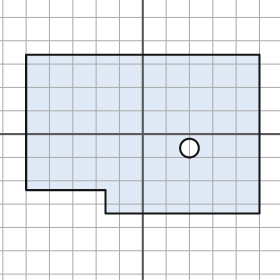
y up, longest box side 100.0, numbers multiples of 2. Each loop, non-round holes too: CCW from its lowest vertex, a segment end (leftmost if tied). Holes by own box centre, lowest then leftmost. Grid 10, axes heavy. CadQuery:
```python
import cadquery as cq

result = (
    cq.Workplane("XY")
    .moveTo(-16.0, -34.0)
    .lineTo(50.0, -34.0)
    .lineTo(50.0, 34.0)
    .lineTo(-50.0, 34.0)
    .lineTo(-50.0, -24.0)
    .lineTo(-16.0, -24.0)
    .close()
    .moveTo(20.0, -6.0)
    .circle(4.0)
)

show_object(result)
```